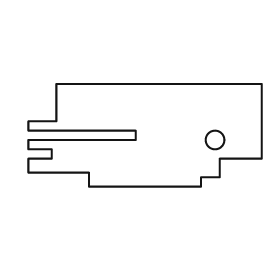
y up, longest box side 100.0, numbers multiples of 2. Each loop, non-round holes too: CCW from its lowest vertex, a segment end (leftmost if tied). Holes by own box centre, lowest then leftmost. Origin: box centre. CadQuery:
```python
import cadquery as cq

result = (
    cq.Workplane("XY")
    .moveTo(-24.0, -22.0)
    .lineTo(24.0, -22.0)
    .lineTo(24.0, -18.0)
    .lineTo(32.0, -18.0)
    .lineTo(32.0, -10.0)
    .lineTo(50.0, -10.0)
    .lineTo(50.0, 22.0)
    .lineTo(-38.0, 22.0)
    .lineTo(-38.0, 6.0)
    .lineTo(-50.0, 6.0)
    .lineTo(-50.0, 2.0)
    .lineTo(-4.0, 2.0)
    .lineTo(-4.0, -2.0)
    .lineTo(-50.0, -2.0)
    .lineTo(-50.0, -6.0)
    .lineTo(-40.0, -6.0)
    .lineTo(-40.0, -10.0)
    .lineTo(-50.0, -10.0)
    .lineTo(-50.0, -16.0)
    .lineTo(-24.0, -16.0)
    .close()
    .moveTo(30.0, -2.0)
    .circle(4.0)
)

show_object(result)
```